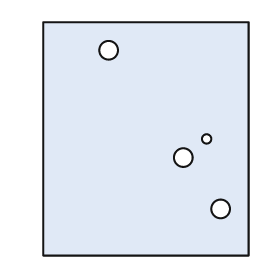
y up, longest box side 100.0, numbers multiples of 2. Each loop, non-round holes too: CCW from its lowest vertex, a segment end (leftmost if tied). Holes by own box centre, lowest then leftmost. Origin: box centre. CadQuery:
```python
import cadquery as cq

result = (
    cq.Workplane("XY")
    .moveTo(-44.0, -50.0)
    .lineTo(44.0, -50.0)
    .lineTo(44.0, 50.0)
    .lineTo(-44.0, 50.0)
    .close()
    .moveTo(32.0, -30.0)
    .circle(4.0)
    .moveTo(16.0, -8.0)
    .circle(4.0)
    .moveTo(26.0, 0.0)
    .circle(2.0)
    .moveTo(-16.0, 38.0)
    .circle(4.0)
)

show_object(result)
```